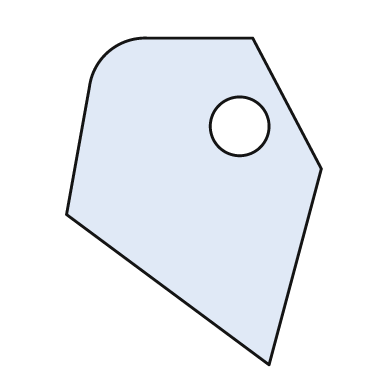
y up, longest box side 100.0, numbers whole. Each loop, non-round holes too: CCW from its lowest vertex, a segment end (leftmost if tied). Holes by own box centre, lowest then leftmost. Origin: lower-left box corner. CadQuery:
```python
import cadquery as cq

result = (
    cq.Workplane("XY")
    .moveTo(62.0, 0.0)
    .lineTo(78.0, 60.0)
    .lineTo(57.0, 100.0)
    .lineTo(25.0, 100.0)
    .threePointArc((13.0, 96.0), (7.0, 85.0))
    .lineTo(0.0, 46.0)
    .close()
    .moveTo(53.0, 73.0)
    .circle(9.0)
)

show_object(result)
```